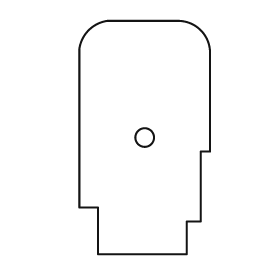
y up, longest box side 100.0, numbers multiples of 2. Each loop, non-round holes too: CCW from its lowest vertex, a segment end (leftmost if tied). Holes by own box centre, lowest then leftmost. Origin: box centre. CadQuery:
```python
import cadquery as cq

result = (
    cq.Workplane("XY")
    .moveTo(-20.0, -50.0)
    .lineTo(18.0, -50.0)
    .lineTo(18.0, -36.0)
    .lineTo(24.0, -36.0)
    .lineTo(24.0, -6.0)
    .lineTo(28.0, -6.0)
    .lineTo(28.0, 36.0)
    .threePointArc((24.0, 46.0), (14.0, 50.0))
    .lineTo(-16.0, 50.0)
    .threePointArc((-24.0, 46.0), (-28.0, 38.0))
    .lineTo(-28.0, -30.0)
    .lineTo(-20.0, -30.0)
    .close()
    .moveTo(0.0, 0.0)
    .circle(4.0)
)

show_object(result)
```